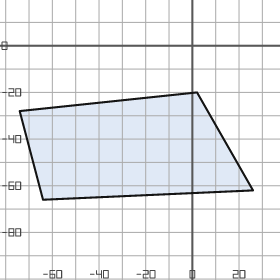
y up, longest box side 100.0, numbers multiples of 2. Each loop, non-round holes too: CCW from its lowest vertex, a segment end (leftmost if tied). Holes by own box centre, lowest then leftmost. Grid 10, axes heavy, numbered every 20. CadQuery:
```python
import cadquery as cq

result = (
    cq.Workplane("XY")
    .moveTo(-64.0, -66.0)
    .lineTo(26.0, -62.0)
    .lineTo(2.0, -20.0)
    .lineTo(-74.0, -28.0)
    .close()
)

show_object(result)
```